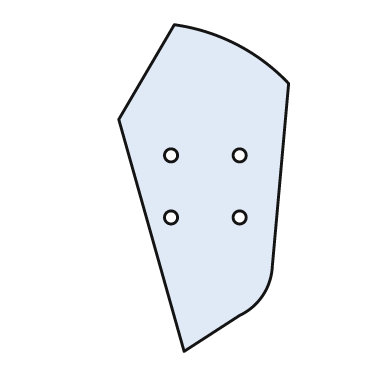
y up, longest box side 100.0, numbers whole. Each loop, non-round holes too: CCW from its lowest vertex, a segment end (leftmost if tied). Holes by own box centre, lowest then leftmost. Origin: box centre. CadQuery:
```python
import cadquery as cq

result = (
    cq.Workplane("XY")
    .moveTo(-6.0, -50.0)
    .lineTo(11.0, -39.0)
    .threePointArc((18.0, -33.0), (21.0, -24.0))
    .lineTo(26.0, 32.0)
    .threePointArc((10.0, 44.0), (-9.0, 50.0))
    .lineTo(-26.0, 21.0)
    .close()
    .moveTo(-10.0, -9.0)
    .circle(2.0)
    .moveTo(11.0, -9.0)
    .circle(2.0)
    .moveTo(-10.0, 10.0)
    .circle(2.0)
    .moveTo(11.0, 10.0)
    .circle(2.0)
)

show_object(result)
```